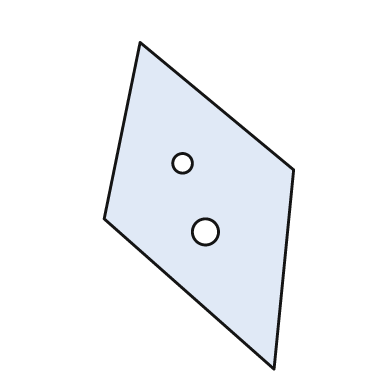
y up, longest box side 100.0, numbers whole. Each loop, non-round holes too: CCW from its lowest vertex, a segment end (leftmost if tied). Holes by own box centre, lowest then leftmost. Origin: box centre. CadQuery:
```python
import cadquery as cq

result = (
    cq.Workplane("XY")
    .moveTo(23.0, -50.0)
    .lineTo(29.0, 11.0)
    .lineTo(-18.0, 50.0)
    .lineTo(-29.0, -4.0)
    .close()
    .moveTo(2.0, -8.0)
    .circle(4.0)
    .moveTo(-5.0, 13.0)
    .circle(3.0)
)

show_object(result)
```